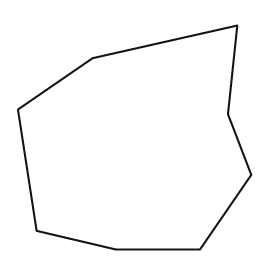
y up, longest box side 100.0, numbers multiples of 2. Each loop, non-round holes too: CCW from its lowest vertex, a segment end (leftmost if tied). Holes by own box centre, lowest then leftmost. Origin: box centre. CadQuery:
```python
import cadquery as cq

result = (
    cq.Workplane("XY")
    .moveTo(-8.0, -48.0)
    .lineTo(28.0, -48.0)
    .lineTo(50.0, -16.0)
    .lineTo(40.0, 10.0)
    .lineTo(44.0, 48.0)
    .lineTo(-18.0, 34.0)
    .lineTo(-50.0, 12.0)
    .lineTo(-42.0, -40.0)
    .close()
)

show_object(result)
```